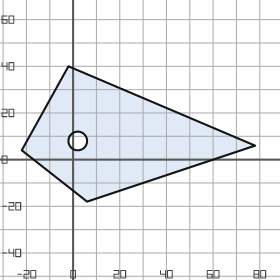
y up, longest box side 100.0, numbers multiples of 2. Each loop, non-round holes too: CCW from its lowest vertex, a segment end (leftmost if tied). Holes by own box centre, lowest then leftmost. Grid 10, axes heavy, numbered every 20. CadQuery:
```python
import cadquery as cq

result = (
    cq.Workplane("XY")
    .moveTo(6.0, -18.0)
    .lineTo(78.0, 6.0)
    .lineTo(-2.0, 40.0)
    .lineTo(-22.0, 4.0)
    .close()
    .moveTo(2.0, 8.0)
    .circle(4.0)
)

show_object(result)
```